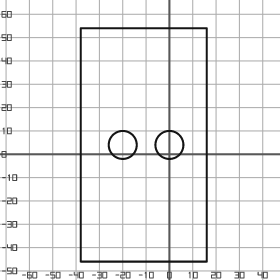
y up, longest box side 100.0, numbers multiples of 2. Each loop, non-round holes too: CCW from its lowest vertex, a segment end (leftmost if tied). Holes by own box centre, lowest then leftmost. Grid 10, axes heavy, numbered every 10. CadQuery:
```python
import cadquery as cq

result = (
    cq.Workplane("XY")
    .moveTo(-38.0, -46.0)
    .lineTo(16.0, -46.0)
    .lineTo(16.0, 54.0)
    .lineTo(-38.0, 54.0)
    .close()
    .moveTo(-20.0, 4.0)
    .circle(6.0)
    .moveTo(0.0, 4.0)
    .circle(6.0)
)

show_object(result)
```